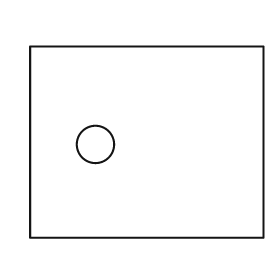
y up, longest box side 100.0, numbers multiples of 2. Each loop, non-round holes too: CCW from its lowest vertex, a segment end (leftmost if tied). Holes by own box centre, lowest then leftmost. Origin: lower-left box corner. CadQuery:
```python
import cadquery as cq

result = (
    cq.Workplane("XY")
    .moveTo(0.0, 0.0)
    .lineTo(100.0, 0.0)
    .lineTo(100.0, 82.0)
    .lineTo(0.0, 82.0)
    .close()
    .moveTo(28.0, 40.0)
    .circle(8.0)
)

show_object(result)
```